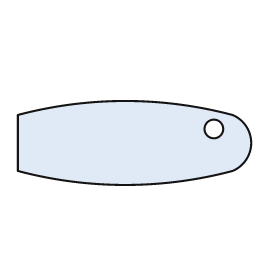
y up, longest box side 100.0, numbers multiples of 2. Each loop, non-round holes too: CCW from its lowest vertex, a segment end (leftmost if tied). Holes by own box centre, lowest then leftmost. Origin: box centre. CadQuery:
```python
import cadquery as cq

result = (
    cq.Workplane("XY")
    .moveTo(-50.0, -12.0)
    .threePointArc((-4.0, -18.0), (42.0, -12.0))
    .threePointArc((50.0, 0.0), (42.0, 12.0))
    .threePointArc((-4.0, 18.0), (-50.0, 12.0))
    .close()
    .moveTo(34.0, 6.0)
    .circle(4.0)
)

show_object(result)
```